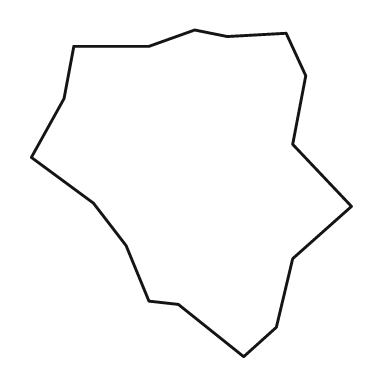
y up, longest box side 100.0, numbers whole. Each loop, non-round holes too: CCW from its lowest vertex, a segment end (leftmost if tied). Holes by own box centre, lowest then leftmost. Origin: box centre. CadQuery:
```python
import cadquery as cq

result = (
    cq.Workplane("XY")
    .moveTo(16.0, -50.0)
    .lineTo(26.0, -41.0)
    .lineTo(31.0, -20.0)
    .lineTo(49.0, -4.0)
    .lineTo(31.0, 15.0)
    .lineTo(35.0, 36.0)
    .lineTo(29.0, 49.0)
    .lineTo(11.0, 48.0)
    .lineTo(1.0, 50.0)
    .lineTo(-13.0, 45.0)
    .lineTo(-36.0, 45.0)
    .lineTo(-39.0, 29.0)
    .lineTo(-49.0, 11.0)
    .lineTo(-30.0, -3.0)
    .lineTo(-20.0, -16.0)
    .lineTo(-13.0, -33.0)
    .lineTo(-4.0, -34.0)
    .close()
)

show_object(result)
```